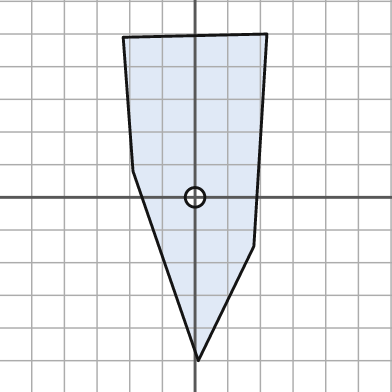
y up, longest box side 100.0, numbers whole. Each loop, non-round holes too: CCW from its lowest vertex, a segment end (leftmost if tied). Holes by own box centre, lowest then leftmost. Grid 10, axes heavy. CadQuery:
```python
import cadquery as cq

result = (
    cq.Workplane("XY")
    .moveTo(1.0, -50.0)
    .lineTo(18.0, -15.0)
    .lineTo(22.0, 50.0)
    .lineTo(-22.0, 49.0)
    .lineTo(-19.0, 8.0)
    .close()
    .moveTo(0.0, 0.0)
    .circle(3.0)
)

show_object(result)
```